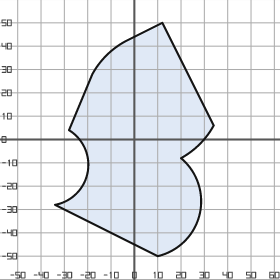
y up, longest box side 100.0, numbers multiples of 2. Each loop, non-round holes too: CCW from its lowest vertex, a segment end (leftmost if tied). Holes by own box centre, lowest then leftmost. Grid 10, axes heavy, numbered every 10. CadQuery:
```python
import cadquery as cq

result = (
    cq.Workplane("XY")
    .moveTo(10.0, -50.0)
    .threePointArc((28.0, -32.0), (20.0, -8.0))
    .threePointArc((28.0, -2.0), (34.0, 6.0))
    .lineTo(12.0, 50.0)
    .lineTo(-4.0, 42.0)
    .threePointArc((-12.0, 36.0), (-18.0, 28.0))
    .lineTo(-28.0, 4.0)
    .threePointArc((-20.0, -14.0), (-34.0, -28.0))
    .close()
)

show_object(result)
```